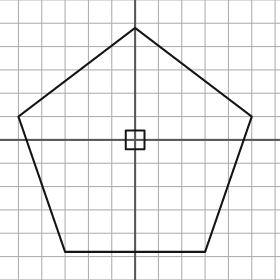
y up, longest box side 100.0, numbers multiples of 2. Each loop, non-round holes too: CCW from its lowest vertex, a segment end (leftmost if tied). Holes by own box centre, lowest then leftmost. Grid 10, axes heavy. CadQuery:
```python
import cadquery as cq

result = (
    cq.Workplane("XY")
    .moveTo(-30.0, -48.0)
    .lineTo(30.0, -48.0)
    .lineTo(50.0, 10.0)
    .lineTo(0.0, 48.0)
    .lineTo(-50.0, 10.0)
    .close()
    .moveTo(-4.0, -4.0)
    .lineTo(4.0, -4.0)
    .lineTo(4.0, 4.0)
    .lineTo(-4.0, 4.0)
    .close()
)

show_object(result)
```